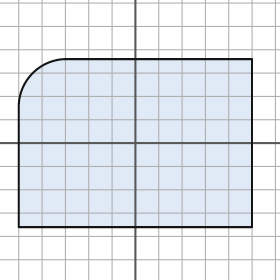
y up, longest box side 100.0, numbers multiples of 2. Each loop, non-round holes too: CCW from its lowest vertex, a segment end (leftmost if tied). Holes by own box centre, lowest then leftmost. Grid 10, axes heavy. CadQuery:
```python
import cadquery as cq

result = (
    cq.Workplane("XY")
    .moveTo(-50.0, -36.0)
    .lineTo(50.0, -36.0)
    .lineTo(50.0, 36.0)
    .lineTo(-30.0, 36.0)
    .threePointArc((-44.0, 30.0), (-50.0, 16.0))
    .close()
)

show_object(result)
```